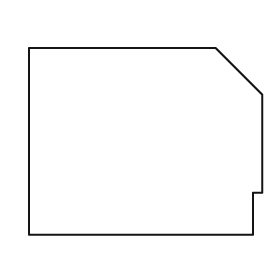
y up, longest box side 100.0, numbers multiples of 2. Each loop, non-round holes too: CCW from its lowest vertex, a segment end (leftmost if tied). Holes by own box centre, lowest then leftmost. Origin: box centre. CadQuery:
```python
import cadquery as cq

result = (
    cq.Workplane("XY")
    .moveTo(-50.0, -40.0)
    .lineTo(46.0, -40.0)
    .lineTo(46.0, -22.0)
    .lineTo(50.0, -22.0)
    .lineTo(50.0, 20.0)
    .lineTo(30.0, 40.0)
    .lineTo(-50.0, 40.0)
    .close()
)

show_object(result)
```